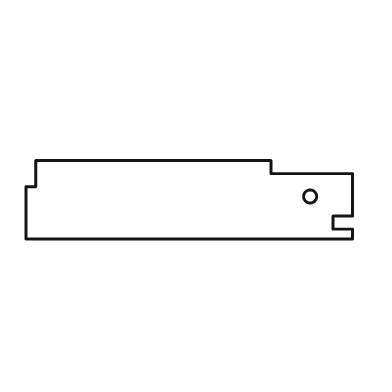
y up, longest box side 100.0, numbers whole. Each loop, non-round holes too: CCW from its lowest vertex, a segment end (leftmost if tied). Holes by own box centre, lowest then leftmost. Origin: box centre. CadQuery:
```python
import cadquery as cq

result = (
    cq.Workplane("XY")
    .moveTo(-50.0, -12.0)
    .lineTo(50.0, -12.0)
    .lineTo(50.0, -9.0)
    .lineTo(44.0, -9.0)
    .lineTo(44.0, -5.0)
    .lineTo(50.0, -5.0)
    .lineTo(50.0, 8.0)
    .lineTo(25.0, 8.0)
    .lineTo(25.0, 12.0)
    .lineTo(-47.0, 12.0)
    .lineTo(-47.0, 4.0)
    .lineTo(-50.0, 4.0)
    .close()
    .moveTo(37.0, 1.0)
    .circle(2.0)
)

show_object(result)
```